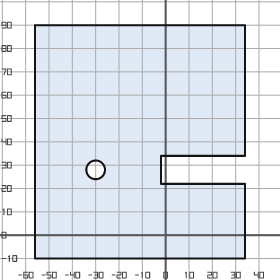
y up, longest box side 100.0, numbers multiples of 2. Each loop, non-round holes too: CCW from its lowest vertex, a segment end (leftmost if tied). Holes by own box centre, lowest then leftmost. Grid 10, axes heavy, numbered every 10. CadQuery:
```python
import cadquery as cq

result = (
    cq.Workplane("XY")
    .moveTo(-56.0, -10.0)
    .lineTo(34.0, -10.0)
    .lineTo(34.0, 22.0)
    .lineTo(-2.0, 22.0)
    .lineTo(-2.0, 34.0)
    .lineTo(34.0, 34.0)
    .lineTo(34.0, 90.0)
    .lineTo(-56.0, 90.0)
    .close()
    .moveTo(-30.0, 28.0)
    .circle(4.0)
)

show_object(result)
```